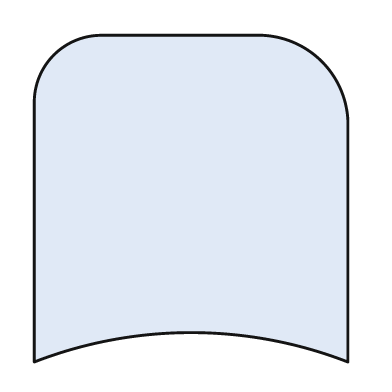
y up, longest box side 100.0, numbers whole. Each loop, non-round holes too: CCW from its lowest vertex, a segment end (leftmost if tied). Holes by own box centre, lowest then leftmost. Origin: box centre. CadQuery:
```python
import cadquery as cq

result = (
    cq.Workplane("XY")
    .moveTo(-48.0, -50.0)
    .threePointArc((0.0, -41.0), (48.0, -50.0))
    .lineTo(48.0, 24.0)
    .threePointArc((40.0, 42.0), (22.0, 50.0))
    .lineTo(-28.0, 50.0)
    .threePointArc((-42.0, 44.0), (-48.0, 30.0))
    .close()
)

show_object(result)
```